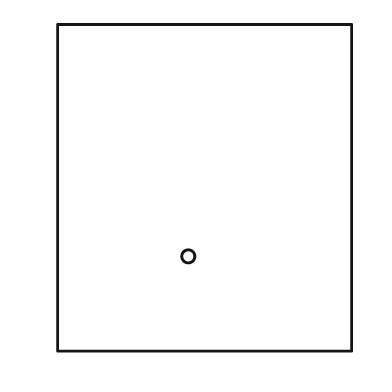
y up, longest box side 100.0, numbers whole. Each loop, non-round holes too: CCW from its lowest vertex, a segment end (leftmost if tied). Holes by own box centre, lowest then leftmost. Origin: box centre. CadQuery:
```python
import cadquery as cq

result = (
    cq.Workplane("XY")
    .moveTo(-45.0, -50.0)
    .lineTo(45.0, -50.0)
    .lineTo(45.0, 50.0)
    .lineTo(-45.0, 50.0)
    .close()
    .moveTo(-5.0, -21.0)
    .circle(2.0)
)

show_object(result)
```